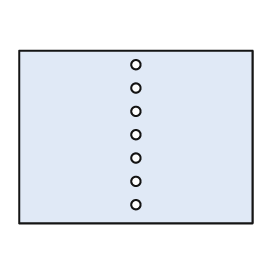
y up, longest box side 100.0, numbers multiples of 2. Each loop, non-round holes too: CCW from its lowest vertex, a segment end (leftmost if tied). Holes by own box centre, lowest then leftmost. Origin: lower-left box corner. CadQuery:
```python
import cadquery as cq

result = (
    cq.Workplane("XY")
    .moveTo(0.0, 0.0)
    .lineTo(100.0, 0.0)
    .lineTo(100.0, 74.0)
    .lineTo(0.0, 74.0)
    .close()
    .moveTo(50.0, 8.0)
    .circle(2.0)
    .moveTo(50.0, 18.0)
    .circle(2.0)
    .moveTo(50.0, 28.0)
    .circle(2.0)
    .moveTo(50.0, 38.0)
    .circle(2.0)
    .moveTo(50.0, 48.0)
    .circle(2.0)
    .moveTo(50.0, 58.0)
    .circle(2.0)
    .moveTo(50.0, 68.0)
    .circle(2.0)
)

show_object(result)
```